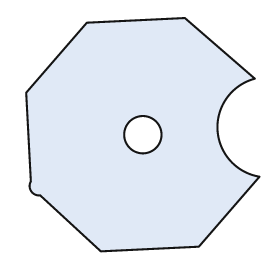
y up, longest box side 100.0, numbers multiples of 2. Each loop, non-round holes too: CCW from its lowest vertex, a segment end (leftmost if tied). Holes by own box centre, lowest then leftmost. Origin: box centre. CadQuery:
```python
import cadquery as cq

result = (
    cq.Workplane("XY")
    .moveTo(-18.0, -50.0)
    .lineTo(24.0, -48.0)
    .lineTo(50.0, -18.0)
    .threePointArc((32.0, 2.0), (48.0, 24.0))
    .lineTo(18.0, 50.0)
    .lineTo(-24.0, 48.0)
    .lineTo(-50.0, 18.0)
    .lineTo(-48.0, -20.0)
    .threePointArc((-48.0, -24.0), (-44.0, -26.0))
    .close()
    .moveTo(0.0, 0.0)
    .circle(8.0)
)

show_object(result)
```